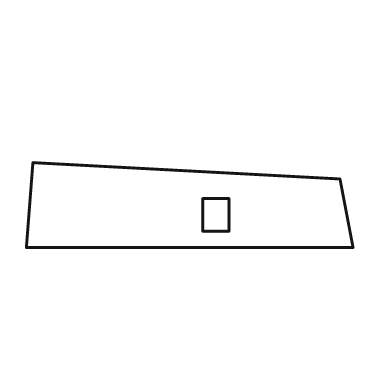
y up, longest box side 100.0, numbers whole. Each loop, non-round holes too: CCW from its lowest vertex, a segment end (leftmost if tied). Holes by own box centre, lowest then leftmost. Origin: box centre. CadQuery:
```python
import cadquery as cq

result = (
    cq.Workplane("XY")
    .moveTo(-50.0, -13.0)
    .lineTo(50.0, -13.0)
    .lineTo(46.0, 8.0)
    .lineTo(-48.0, 13.0)
    .close()
    .moveTo(4.0, -8.0)
    .lineTo(12.0, -8.0)
    .lineTo(12.0, 2.0)
    .lineTo(4.0, 2.0)
    .close()
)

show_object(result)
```